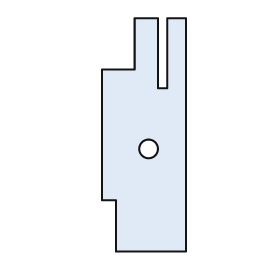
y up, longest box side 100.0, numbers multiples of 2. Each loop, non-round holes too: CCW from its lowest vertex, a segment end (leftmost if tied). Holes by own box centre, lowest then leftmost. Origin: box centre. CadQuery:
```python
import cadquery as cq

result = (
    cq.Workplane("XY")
    .moveTo(-12.0, -50.0)
    .lineTo(18.0, -50.0)
    .lineTo(18.0, 50.0)
    .lineTo(10.0, 50.0)
    .lineTo(10.0, 20.0)
    .lineTo(6.0, 20.0)
    .lineTo(6.0, 50.0)
    .lineTo(-4.0, 50.0)
    .lineTo(-4.0, 28.0)
    .lineTo(-18.0, 28.0)
    .lineTo(-18.0, -28.0)
    .lineTo(-12.0, -28.0)
    .close()
    .moveTo(2.0, -6.0)
    .circle(4.0)
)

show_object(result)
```